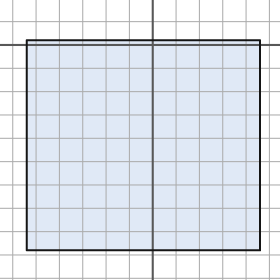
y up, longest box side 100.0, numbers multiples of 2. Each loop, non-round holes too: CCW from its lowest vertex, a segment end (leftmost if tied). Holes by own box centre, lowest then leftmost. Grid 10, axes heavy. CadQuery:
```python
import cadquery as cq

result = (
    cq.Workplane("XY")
    .moveTo(-54.0, -88.0)
    .lineTo(46.0, -88.0)
    .lineTo(46.0, 2.0)
    .lineTo(-54.0, 2.0)
    .close()
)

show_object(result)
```